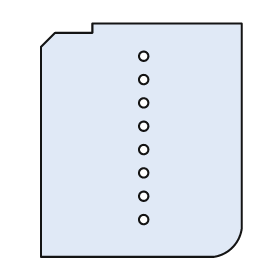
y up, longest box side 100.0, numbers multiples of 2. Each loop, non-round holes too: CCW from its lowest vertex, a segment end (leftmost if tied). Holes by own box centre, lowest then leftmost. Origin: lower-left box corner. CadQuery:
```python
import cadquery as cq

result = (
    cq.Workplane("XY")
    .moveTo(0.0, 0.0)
    .lineTo(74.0, 0.0)
    .threePointArc((82.0, 4.0), (86.0, 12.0))
    .lineTo(86.0, 100.0)
    .lineTo(22.0, 100.0)
    .lineTo(22.0, 96.0)
    .lineTo(6.0, 96.0)
    .lineTo(0.0, 90.0)
    .close()
    .moveTo(44.0, 16.0)
    .circle(2.0)
    .moveTo(44.0, 26.0)
    .circle(2.0)
    .moveTo(44.0, 36.0)
    .circle(2.0)
    .moveTo(44.0, 46.0)
    .circle(2.0)
    .moveTo(44.0, 56.0)
    .circle(2.0)
    .moveTo(44.0, 66.0)
    .circle(2.0)
    .moveTo(44.0, 76.0)
    .circle(2.0)
    .moveTo(44.0, 86.0)
    .circle(2.0)
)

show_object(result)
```